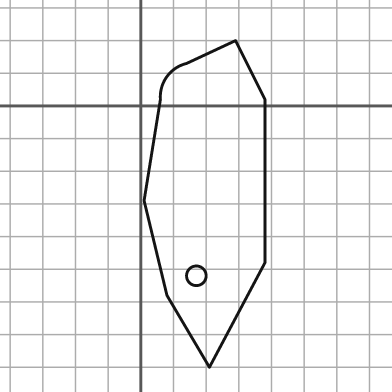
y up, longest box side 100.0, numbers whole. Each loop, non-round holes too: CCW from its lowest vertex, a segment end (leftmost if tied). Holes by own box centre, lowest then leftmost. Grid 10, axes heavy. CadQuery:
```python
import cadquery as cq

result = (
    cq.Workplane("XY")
    .moveTo(21.0, -80.0)
    .lineTo(38.0, -48.0)
    .lineTo(38.0, 2.0)
    .lineTo(29.0, 20.0)
    .lineTo(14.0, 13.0)
    .threePointArc((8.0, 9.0), (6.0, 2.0))
    .lineTo(1.0, -29.0)
    .lineTo(8.0, -58.0)
    .close()
    .moveTo(17.0, -52.0)
    .circle(3.0)
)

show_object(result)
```